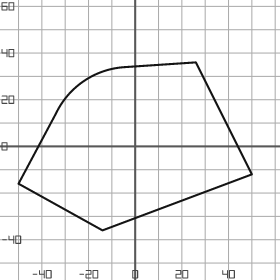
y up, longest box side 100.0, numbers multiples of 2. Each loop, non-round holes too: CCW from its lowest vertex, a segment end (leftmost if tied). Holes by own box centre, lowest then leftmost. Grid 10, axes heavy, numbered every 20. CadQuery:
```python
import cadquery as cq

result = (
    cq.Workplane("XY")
    .moveTo(-14.0, -36.0)
    .lineTo(50.0, -12.0)
    .lineTo(26.0, 36.0)
    .lineTo(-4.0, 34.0)
    .threePointArc((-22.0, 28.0), (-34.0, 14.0))
    .lineTo(-50.0, -16.0)
    .close()
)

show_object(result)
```